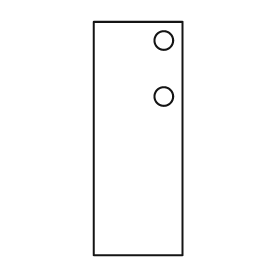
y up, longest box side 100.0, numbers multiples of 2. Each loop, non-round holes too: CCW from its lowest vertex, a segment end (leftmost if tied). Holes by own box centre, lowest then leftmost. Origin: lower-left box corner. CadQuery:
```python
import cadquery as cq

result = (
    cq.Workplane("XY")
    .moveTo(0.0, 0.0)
    .lineTo(38.0, 0.0)
    .lineTo(38.0, 100.0)
    .lineTo(0.0, 100.0)
    .close()
    .moveTo(30.0, 68.0)
    .circle(4.0)
    .moveTo(30.0, 92.0)
    .circle(4.0)
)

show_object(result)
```